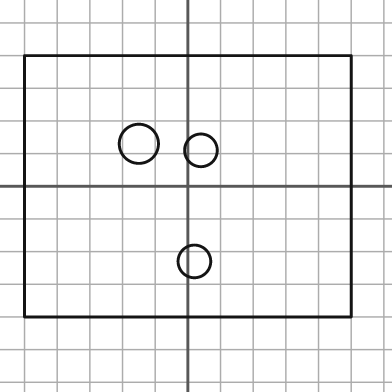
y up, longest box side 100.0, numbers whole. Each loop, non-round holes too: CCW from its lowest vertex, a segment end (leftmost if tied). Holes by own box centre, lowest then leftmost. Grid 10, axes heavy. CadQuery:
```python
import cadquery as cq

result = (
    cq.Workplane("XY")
    .moveTo(-50.0, -40.0)
    .lineTo(50.0, -40.0)
    .lineTo(50.0, 40.0)
    .lineTo(-50.0, 40.0)
    .close()
    .moveTo(2.0, -23.0)
    .circle(5.0)
    .moveTo(4.0, 11.0)
    .circle(5.0)
    .moveTo(-15.0, 13.0)
    .circle(6.0)
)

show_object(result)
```